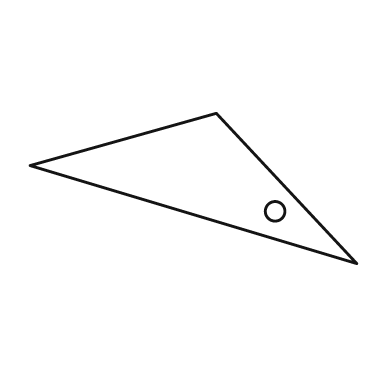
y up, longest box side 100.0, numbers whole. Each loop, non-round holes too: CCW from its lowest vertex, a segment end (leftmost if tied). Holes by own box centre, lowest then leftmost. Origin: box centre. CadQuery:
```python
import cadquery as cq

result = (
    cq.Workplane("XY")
    .moveTo(50.0, -23.0)
    .lineTo(7.0, 23.0)
    .lineTo(-50.0, 7.0)
    .close()
    .moveTo(25.0, -7.0)
    .circle(3.0)
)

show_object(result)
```